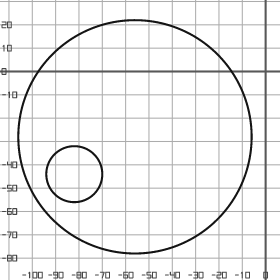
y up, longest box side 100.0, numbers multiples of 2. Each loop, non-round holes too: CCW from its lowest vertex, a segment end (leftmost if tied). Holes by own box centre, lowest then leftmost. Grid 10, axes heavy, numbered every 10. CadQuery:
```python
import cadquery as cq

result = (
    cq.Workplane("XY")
    .moveTo(-56.0, -28.0)
    .circle(50.0)
    .moveTo(-82.0, -44.0)
    .circle(12.0)
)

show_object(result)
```